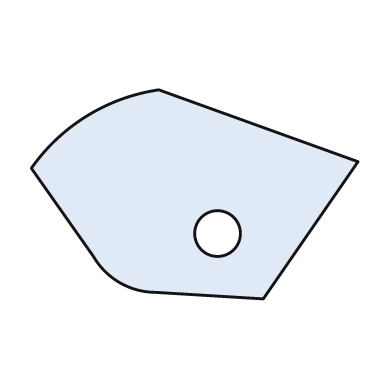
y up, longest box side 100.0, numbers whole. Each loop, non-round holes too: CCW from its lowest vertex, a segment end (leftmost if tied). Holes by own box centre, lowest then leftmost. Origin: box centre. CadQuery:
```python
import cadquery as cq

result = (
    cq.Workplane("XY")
    .moveTo(21.0, -32.0)
    .lineTo(50.0, 10.0)
    .lineTo(-11.0, 32.0)
    .threePointArc((-33.0, 24.0), (-50.0, 8.0))
    .lineTo(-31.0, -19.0)
    .threePointArc((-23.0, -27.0), (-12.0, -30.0))
    .close()
    .moveTo(7.0, -12.0)
    .circle(7.0)
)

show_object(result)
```